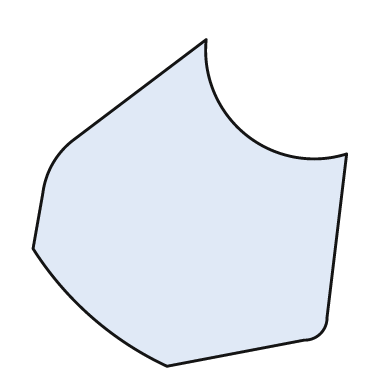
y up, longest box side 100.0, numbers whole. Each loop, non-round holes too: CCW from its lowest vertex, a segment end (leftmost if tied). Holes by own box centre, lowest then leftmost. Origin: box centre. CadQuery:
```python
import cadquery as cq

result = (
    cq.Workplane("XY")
    .moveTo(-7.0, -50.0)
    .lineTo(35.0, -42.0)
    .threePointArc((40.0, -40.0), (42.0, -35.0))
    .lineTo(48.0, 15.0)
    .threePointArc((17.0, 21.0), (5.0, 50.0))
    .lineTo(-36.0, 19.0)
    .threePointArc((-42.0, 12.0), (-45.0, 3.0))
    .lineTo(-48.0, -14.0)
    .threePointArc((-30.0, -35.0), (-7.0, -50.0))
    .close()
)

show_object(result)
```